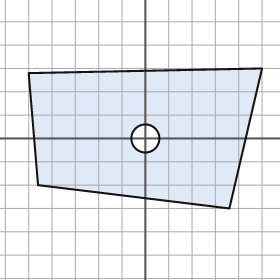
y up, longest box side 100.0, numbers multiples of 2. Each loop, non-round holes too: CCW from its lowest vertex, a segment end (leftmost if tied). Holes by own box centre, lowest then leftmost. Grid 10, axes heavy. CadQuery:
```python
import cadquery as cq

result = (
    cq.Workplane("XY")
    .moveTo(36.0, -30.0)
    .lineTo(50.0, 30.0)
    .lineTo(-50.0, 28.0)
    .lineTo(-46.0, -20.0)
    .close()
    .moveTo(0.0, 0.0)
    .circle(6.0)
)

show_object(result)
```